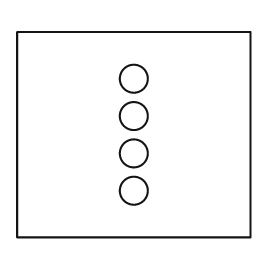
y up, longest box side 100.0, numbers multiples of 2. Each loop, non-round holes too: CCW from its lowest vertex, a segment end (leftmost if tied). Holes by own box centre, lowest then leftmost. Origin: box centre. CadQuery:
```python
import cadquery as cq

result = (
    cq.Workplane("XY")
    .moveTo(-50.0, -44.0)
    .lineTo(50.0, -44.0)
    .lineTo(50.0, 44.0)
    .lineTo(-50.0, 44.0)
    .close()
    .moveTo(0.0, -24.0)
    .circle(6.0)
    .moveTo(0.0, -8.0)
    .circle(6.0)
    .moveTo(0.0, 8.0)
    .circle(6.0)
    .moveTo(0.0, 24.0)
    .circle(6.0)
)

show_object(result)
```